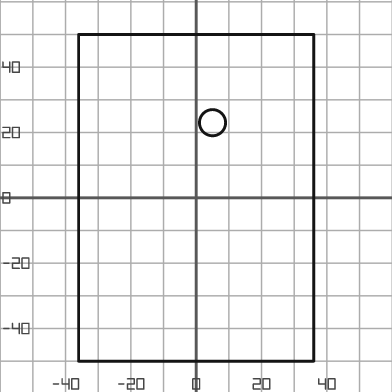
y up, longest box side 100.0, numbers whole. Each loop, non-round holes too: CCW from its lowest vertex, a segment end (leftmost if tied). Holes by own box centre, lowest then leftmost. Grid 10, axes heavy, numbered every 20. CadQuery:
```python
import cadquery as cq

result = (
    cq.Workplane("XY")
    .moveTo(-36.0, -50.0)
    .lineTo(36.0, -50.0)
    .lineTo(36.0, 50.0)
    .lineTo(-36.0, 50.0)
    .close()
    .moveTo(5.0, 23.0)
    .circle(4.0)
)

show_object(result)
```